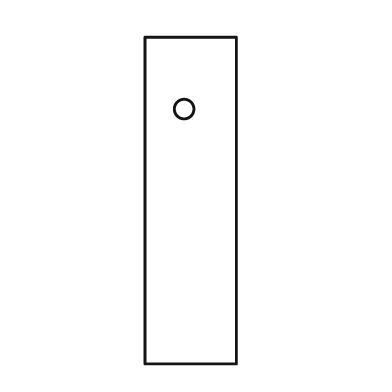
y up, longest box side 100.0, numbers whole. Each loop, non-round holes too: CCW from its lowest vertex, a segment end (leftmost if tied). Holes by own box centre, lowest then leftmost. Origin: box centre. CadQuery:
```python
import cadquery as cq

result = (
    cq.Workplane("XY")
    .moveTo(-14.0, -50.0)
    .lineTo(14.0, -50.0)
    .lineTo(14.0, 50.0)
    .lineTo(-14.0, 50.0)
    .close()
    .moveTo(-2.0, 28.0)
    .circle(3.0)
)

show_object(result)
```